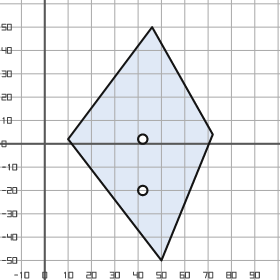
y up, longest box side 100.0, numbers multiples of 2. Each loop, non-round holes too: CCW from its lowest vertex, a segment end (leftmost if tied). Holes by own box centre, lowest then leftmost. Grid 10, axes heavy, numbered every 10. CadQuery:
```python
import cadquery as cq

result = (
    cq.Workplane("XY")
    .moveTo(50.0, -50.0)
    .lineTo(72.0, 4.0)
    .lineTo(46.0, 50.0)
    .lineTo(10.0, 2.0)
    .close()
    .moveTo(42.0, -20.0)
    .circle(2.0)
    .moveTo(42.0, 2.0)
    .circle(2.0)
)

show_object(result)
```